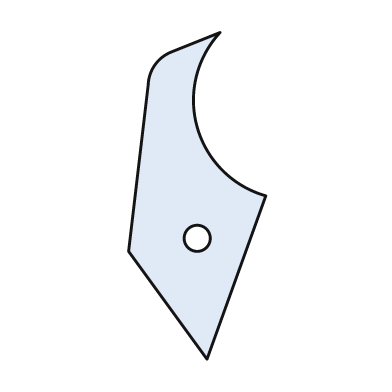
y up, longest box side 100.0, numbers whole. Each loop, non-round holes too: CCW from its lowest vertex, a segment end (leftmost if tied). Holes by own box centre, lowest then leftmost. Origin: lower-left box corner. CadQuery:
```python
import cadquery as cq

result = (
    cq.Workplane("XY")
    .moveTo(24.0, 0.0)
    .lineTo(42.0, 50.0)
    .threePointArc((21.0, 71.0), (28.0, 100.0))
    .lineTo(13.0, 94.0)
    .threePointArc((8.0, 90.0), (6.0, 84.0))
    .lineTo(0.0, 33.0)
    .close()
    .moveTo(21.0, 37.0)
    .circle(4.0)
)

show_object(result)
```